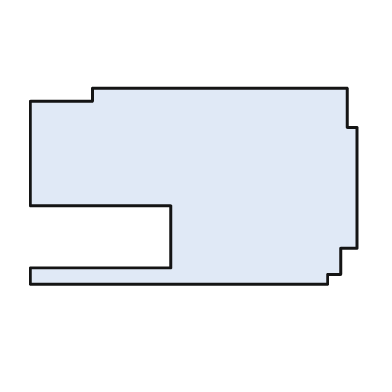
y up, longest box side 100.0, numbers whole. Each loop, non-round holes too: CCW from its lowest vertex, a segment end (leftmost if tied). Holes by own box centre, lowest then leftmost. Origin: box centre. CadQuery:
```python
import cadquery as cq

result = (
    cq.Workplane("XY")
    .moveTo(-50.0, -30.0)
    .lineTo(41.0, -30.0)
    .lineTo(41.0, -27.0)
    .lineTo(45.0, -27.0)
    .lineTo(45.0, -19.0)
    .lineTo(50.0, -19.0)
    .lineTo(50.0, 18.0)
    .lineTo(47.0, 18.0)
    .lineTo(47.0, 30.0)
    .lineTo(-31.0, 30.0)
    .lineTo(-31.0, 26.0)
    .lineTo(-50.0, 26.0)
    .lineTo(-50.0, -6.0)
    .lineTo(-7.0, -6.0)
    .lineTo(-7.0, -25.0)
    .lineTo(-50.0, -25.0)
    .close()
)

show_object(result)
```